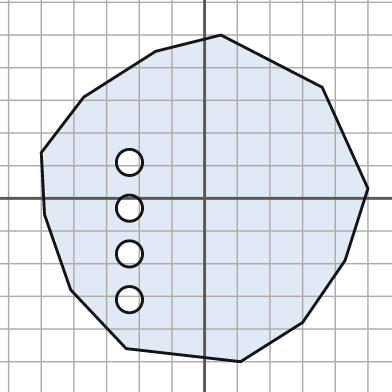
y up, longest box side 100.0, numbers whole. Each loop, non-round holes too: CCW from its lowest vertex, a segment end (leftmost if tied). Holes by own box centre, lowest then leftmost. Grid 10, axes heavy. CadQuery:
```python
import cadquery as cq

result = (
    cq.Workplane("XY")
    .moveTo(11.0, -50.0)
    .lineTo(30.0, -38.0)
    .lineTo(43.0, -19.0)
    .lineTo(50.0, 3.0)
    .lineTo(36.0, 34.0)
    .lineTo(5.0, 50.0)
    .lineTo(-15.0, 45.0)
    .lineTo(-37.0, 31.0)
    .lineTo(-50.0, 14.0)
    .lineTo(-49.0, -5.0)
    .lineTo(-41.0, -28.0)
    .lineTo(-24.0, -46.0)
    .close()
    .moveTo(-23.0, -31.0)
    .circle(4.0)
    .moveTo(-23.0, -17.0)
    .circle(4.0)
    .moveTo(-23.0, -3.0)
    .circle(4.0)
    .moveTo(-23.0, 11.0)
    .circle(4.0)
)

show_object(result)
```